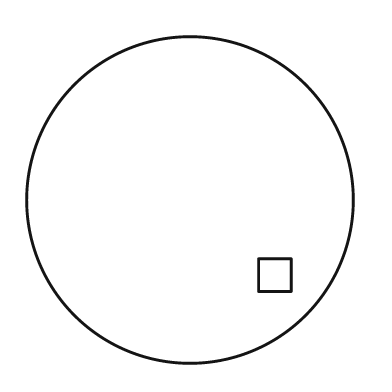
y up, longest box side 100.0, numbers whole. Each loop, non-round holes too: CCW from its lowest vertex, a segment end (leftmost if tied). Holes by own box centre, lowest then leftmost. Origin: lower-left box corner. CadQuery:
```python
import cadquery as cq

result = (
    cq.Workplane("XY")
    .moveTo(50.0, 50.0)
    .circle(50.0)
    .moveTo(71.0, 22.0)
    .lineTo(81.0, 22.0)
    .lineTo(81.0, 32.0)
    .lineTo(71.0, 32.0)
    .close()
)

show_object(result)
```